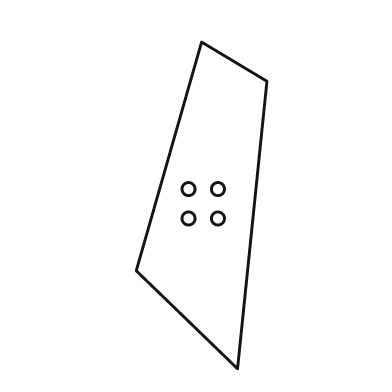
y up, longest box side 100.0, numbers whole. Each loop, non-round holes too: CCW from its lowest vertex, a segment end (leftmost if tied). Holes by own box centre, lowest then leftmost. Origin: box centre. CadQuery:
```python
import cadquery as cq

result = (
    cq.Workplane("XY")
    .moveTo(11.0, -50.0)
    .lineTo(20.0, 38.0)
    .lineTo(0.0, 50.0)
    .lineTo(-20.0, -20.0)
    .close()
    .moveTo(-4.0, -4.0)
    .circle(2.0)
    .moveTo(5.0, -4.0)
    .circle(2.0)
    .moveTo(-4.0, 5.0)
    .circle(2.0)
    .moveTo(5.0, 5.0)
    .circle(2.0)
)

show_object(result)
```